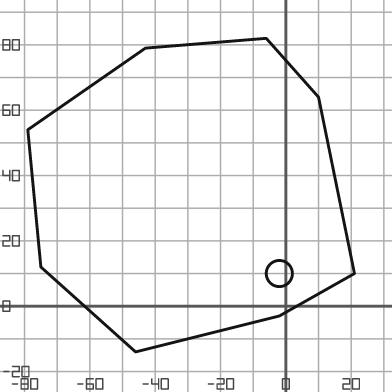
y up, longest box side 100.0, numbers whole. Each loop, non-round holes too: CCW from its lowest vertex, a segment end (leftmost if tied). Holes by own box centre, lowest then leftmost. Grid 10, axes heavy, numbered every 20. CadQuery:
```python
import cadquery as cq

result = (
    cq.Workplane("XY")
    .moveTo(-46.0, -14.0)
    .lineTo(-2.0, -3.0)
    .lineTo(21.0, 10.0)
    .lineTo(10.0, 64.0)
    .lineTo(-6.0, 82.0)
    .lineTo(-43.0, 79.0)
    .lineTo(-79.0, 54.0)
    .lineTo(-75.0, 12.0)
    .close()
    .moveTo(-2.0, 10.0)
    .circle(4.0)
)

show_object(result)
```